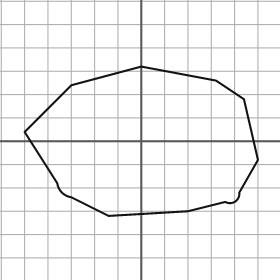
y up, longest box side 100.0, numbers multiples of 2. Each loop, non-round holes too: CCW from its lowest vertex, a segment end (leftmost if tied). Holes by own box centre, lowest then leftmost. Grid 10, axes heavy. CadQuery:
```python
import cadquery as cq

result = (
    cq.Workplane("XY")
    .moveTo(-14.0, -32.0)
    .lineTo(20.0, -30.0)
    .lineTo(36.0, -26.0)
    .threePointArc((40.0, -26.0), (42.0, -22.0))
    .lineTo(50.0, -8.0)
    .lineTo(44.0, 18.0)
    .lineTo(32.0, 26.0)
    .lineTo(0.0, 32.0)
    .lineTo(-30.0, 24.0)
    .lineTo(-50.0, 4.0)
    .lineTo(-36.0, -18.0)
    .threePointArc((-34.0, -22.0), (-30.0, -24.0))
    .close()
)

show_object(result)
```